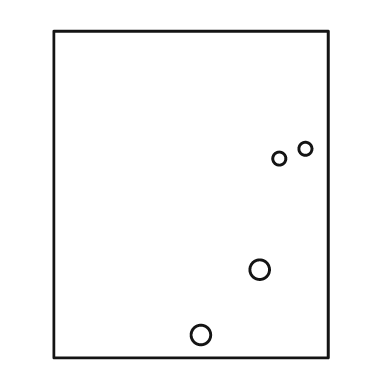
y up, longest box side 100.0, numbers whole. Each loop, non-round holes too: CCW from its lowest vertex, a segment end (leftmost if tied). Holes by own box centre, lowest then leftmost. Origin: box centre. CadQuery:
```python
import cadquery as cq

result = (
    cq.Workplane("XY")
    .moveTo(-42.0, -50.0)
    .lineTo(42.0, -50.0)
    .lineTo(42.0, 50.0)
    .lineTo(-42.0, 50.0)
    .close()
    .moveTo(3.0, -43.0)
    .circle(3.0)
    .moveTo(21.0, -23.0)
    .circle(3.0)
    .moveTo(27.0, 11.0)
    .circle(2.0)
    .moveTo(35.0, 14.0)
    .circle(2.0)
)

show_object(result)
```